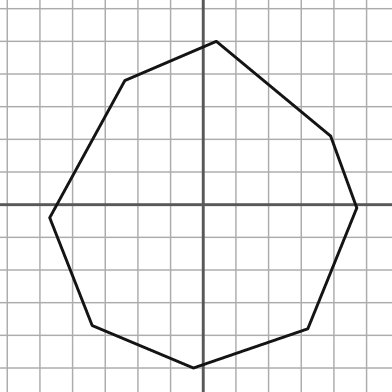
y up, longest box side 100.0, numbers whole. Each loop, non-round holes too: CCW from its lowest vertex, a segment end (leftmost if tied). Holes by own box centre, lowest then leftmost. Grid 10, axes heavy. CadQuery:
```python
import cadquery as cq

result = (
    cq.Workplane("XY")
    .moveTo(-3.0, -50.0)
    .lineTo(32.0, -38.0)
    .lineTo(47.0, -1.0)
    .lineTo(39.0, 21.0)
    .lineTo(4.0, 50.0)
    .lineTo(-24.0, 38.0)
    .lineTo(-47.0, -4.0)
    .lineTo(-34.0, -37.0)
    .close()
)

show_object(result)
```